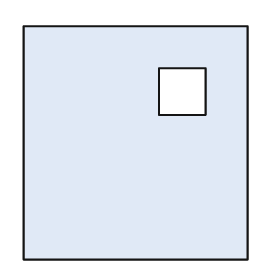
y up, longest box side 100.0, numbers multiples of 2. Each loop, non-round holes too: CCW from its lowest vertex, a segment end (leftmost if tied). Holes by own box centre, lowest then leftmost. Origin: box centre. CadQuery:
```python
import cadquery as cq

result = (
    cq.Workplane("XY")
    .moveTo(-48.0, -50.0)
    .lineTo(48.0, -50.0)
    .lineTo(48.0, 50.0)
    .lineTo(-48.0, 50.0)
    .close()
    .moveTo(10.0, 12.0)
    .lineTo(30.0, 12.0)
    .lineTo(30.0, 32.0)
    .lineTo(10.0, 32.0)
    .close()
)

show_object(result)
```